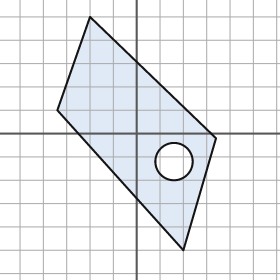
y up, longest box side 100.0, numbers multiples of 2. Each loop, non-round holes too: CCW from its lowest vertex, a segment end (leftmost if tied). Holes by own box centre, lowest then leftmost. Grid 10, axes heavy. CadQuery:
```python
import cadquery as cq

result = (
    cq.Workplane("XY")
    .moveTo(20.0, -50.0)
    .lineTo(34.0, -2.0)
    .lineTo(-20.0, 50.0)
    .lineTo(-34.0, 10.0)
    .close()
    .moveTo(16.0, -12.0)
    .circle(8.0)
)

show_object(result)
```